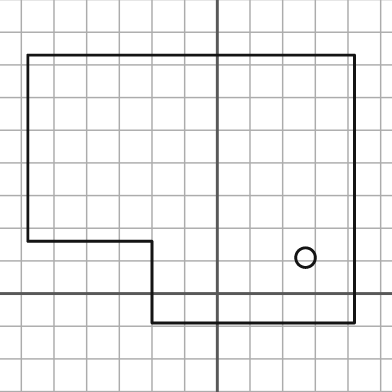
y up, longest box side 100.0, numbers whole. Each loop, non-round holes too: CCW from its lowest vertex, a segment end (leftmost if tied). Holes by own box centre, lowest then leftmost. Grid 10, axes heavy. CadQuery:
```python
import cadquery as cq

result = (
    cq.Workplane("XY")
    .moveTo(-20.0, -9.0)
    .lineTo(42.0, -9.0)
    .lineTo(42.0, 73.0)
    .lineTo(-58.0, 73.0)
    .lineTo(-58.0, 16.0)
    .lineTo(-20.0, 16.0)
    .close()
    .moveTo(27.0, 11.0)
    .circle(3.0)
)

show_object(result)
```